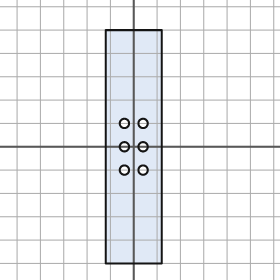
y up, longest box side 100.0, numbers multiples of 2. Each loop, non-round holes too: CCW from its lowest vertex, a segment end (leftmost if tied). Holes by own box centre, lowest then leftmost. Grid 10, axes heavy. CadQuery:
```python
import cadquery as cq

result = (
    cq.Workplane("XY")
    .moveTo(-12.0, -50.0)
    .lineTo(12.0, -50.0)
    .lineTo(12.0, 50.0)
    .lineTo(-12.0, 50.0)
    .close()
    .moveTo(-4.0, -10.0)
    .circle(2.0)
    .moveTo(4.0, -10.0)
    .circle(2.0)
    .moveTo(-4.0, 0.0)
    .circle(2.0)
    .moveTo(4.0, 0.0)
    .circle(2.0)
    .moveTo(-4.0, 10.0)
    .circle(2.0)
    .moveTo(4.0, 10.0)
    .circle(2.0)
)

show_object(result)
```